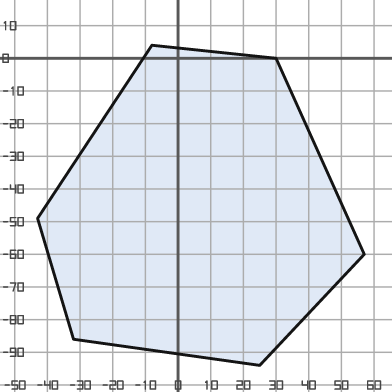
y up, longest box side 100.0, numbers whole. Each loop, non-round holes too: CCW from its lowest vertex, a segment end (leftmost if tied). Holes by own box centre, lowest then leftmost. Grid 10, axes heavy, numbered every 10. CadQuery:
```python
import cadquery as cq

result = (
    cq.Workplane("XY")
    .moveTo(25.0, -94.0)
    .lineTo(57.0, -60.0)
    .lineTo(30.0, 0.0)
    .lineTo(-8.0, 4.0)
    .lineTo(-43.0, -49.0)
    .lineTo(-32.0, -86.0)
    .close()
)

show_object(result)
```